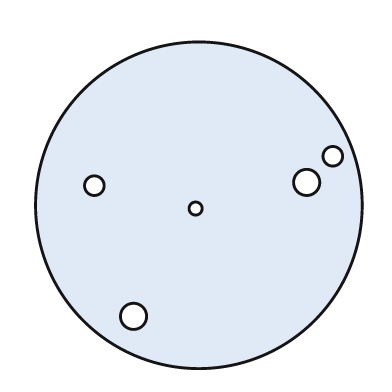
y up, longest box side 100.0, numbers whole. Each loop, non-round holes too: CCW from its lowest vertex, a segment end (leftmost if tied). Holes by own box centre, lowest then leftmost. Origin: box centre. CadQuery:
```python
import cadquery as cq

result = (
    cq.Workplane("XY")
    .moveTo(0.0, 0.0)
    .circle(50.0)
    .moveTo(-20.0, -34.0)
    .circle(4.0)
    .moveTo(-1.0, -1.0)
    .circle(2.0)
    .moveTo(-32.0, 6.0)
    .circle(3.0)
    .moveTo(33.0, 7.0)
    .circle(4.0)
    .moveTo(41.0, 15.0)
    .circle(3.0)
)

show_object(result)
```